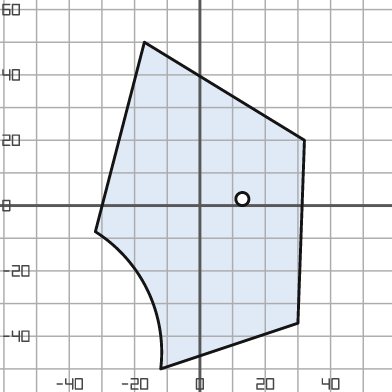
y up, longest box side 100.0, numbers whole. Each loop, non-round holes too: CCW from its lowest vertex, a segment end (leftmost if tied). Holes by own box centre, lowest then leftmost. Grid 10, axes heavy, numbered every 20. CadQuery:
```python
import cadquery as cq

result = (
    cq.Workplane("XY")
    .moveTo(-12.0, -50.0)
    .lineTo(30.0, -36.0)
    .lineTo(32.0, 20.0)
    .lineTo(-17.0, 50.0)
    .lineTo(-32.0, -8.0)
    .threePointArc((-16.0, -26.0), (-12.0, -50.0))
    .close()
    .moveTo(13.0, 2.0)
    .circle(2.0)
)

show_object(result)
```